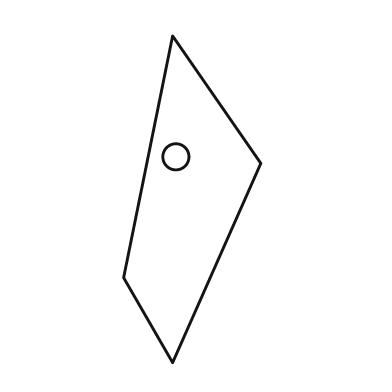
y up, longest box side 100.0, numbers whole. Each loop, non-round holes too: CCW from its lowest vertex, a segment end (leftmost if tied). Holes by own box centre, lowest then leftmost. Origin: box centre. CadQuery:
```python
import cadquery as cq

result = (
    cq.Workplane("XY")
    .moveTo(-6.0, -50.0)
    .lineTo(21.0, 11.0)
    .lineTo(-6.0, 50.0)
    .lineTo(-21.0, -24.0)
    .close()
    .moveTo(-5.0, 13.0)
    .circle(4.0)
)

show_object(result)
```